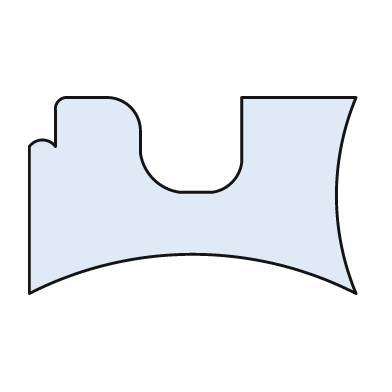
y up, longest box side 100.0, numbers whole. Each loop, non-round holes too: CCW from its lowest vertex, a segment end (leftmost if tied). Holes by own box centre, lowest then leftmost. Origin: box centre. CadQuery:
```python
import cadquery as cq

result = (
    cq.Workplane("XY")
    .moveTo(-50.0, -30.0)
    .threePointArc((0.0, -18.0), (50.0, -30.0))
    .threePointArc((44.0, 0.0), (50.0, 30.0))
    .lineTo(15.0, 30.0)
    .lineTo(15.0, 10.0)
    .threePointArc((12.0, 4.0), (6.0, 1.0))
    .lineTo(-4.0, 1.0)
    .threePointArc((-12.0, 5.0), (-16.0, 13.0))
    .lineTo(-16.0, 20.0)
    .threePointArc((-19.0, 27.0), (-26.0, 30.0))
    .lineTo(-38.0, 30.0)
    .threePointArc((-41.0, 29.0), (-42.0, 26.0))
    .lineTo(-42.0, 15.0)
    .threePointArc((-46.0, 17.0), (-50.0, 15.0))
    .close()
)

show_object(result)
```